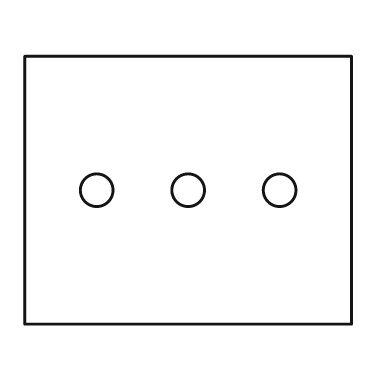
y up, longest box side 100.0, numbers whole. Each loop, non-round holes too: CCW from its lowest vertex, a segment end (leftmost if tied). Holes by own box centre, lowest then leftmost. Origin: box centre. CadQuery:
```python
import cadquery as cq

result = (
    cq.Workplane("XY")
    .moveTo(-50.0, -41.0)
    .lineTo(50.0, -41.0)
    .lineTo(50.0, 41.0)
    .lineTo(-50.0, 41.0)
    .close()
    .moveTo(-28.0, 0.0)
    .circle(5.0)
    .moveTo(0.0, 0.0)
    .circle(5.0)
    .moveTo(28.0, 0.0)
    .circle(5.0)
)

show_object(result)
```